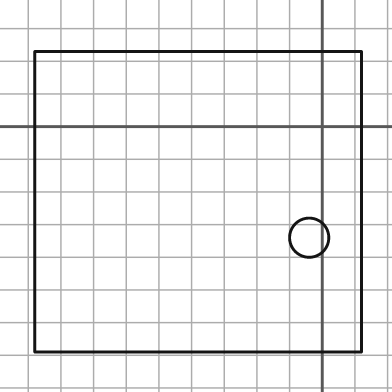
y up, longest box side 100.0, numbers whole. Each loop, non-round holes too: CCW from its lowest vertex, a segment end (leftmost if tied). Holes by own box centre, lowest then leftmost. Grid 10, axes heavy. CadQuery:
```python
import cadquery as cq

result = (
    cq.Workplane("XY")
    .moveTo(-88.0, -69.0)
    .lineTo(12.0, -69.0)
    .lineTo(12.0, 23.0)
    .lineTo(-88.0, 23.0)
    .close()
    .moveTo(-4.0, -34.0)
    .circle(6.0)
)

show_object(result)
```